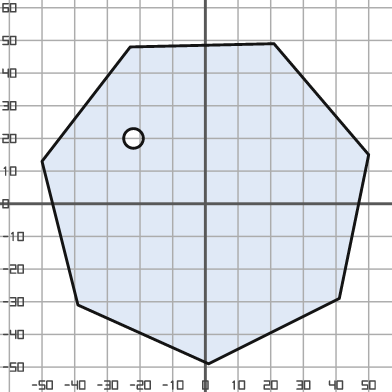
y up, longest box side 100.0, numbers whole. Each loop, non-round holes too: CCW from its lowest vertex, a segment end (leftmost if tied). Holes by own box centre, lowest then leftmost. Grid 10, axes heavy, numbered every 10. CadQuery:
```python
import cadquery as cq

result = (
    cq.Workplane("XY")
    .moveTo(1.0, -49.0)
    .lineTo(41.0, -29.0)
    .lineTo(50.0, 15.0)
    .lineTo(21.0, 49.0)
    .lineTo(-23.0, 48.0)
    .lineTo(-50.0, 13.0)
    .lineTo(-39.0, -31.0)
    .close()
    .moveTo(-22.0, 20.0)
    .circle(3.0)
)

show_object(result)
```